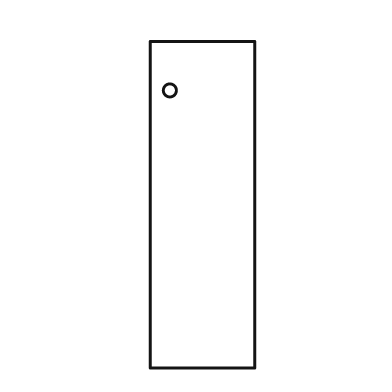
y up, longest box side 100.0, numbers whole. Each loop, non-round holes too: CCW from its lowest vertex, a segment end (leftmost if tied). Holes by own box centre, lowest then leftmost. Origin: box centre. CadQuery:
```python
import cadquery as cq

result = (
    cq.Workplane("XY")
    .moveTo(-16.0, -50.0)
    .lineTo(16.0, -50.0)
    .lineTo(16.0, 50.0)
    .lineTo(-16.0, 50.0)
    .close()
    .moveTo(-10.0, 35.0)
    .circle(2.0)
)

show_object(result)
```